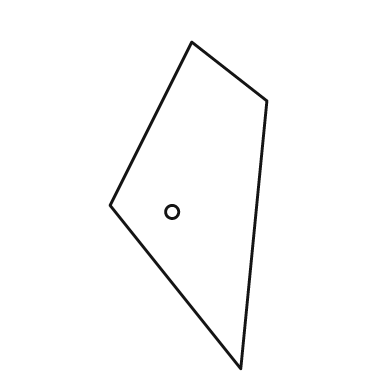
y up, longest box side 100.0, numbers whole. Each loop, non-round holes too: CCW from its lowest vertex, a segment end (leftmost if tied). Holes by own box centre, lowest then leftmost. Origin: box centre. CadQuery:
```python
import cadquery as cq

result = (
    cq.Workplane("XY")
    .moveTo(16.0, -50.0)
    .lineTo(24.0, 32.0)
    .lineTo(1.0, 50.0)
    .lineTo(-24.0, 0.0)
    .close()
    .moveTo(-5.0, -2.0)
    .circle(2.0)
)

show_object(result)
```